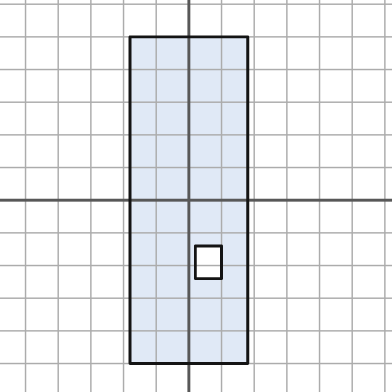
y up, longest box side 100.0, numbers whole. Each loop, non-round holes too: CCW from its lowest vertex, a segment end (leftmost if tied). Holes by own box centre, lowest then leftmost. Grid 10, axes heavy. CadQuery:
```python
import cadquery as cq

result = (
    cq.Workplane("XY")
    .moveTo(-18.0, -50.0)
    .lineTo(18.0, -50.0)
    .lineTo(18.0, 50.0)
    .lineTo(-18.0, 50.0)
    .close()
    .moveTo(2.0, -24.0)
    .lineTo(10.0, -24.0)
    .lineTo(10.0, -14.0)
    .lineTo(2.0, -14.0)
    .close()
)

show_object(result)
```